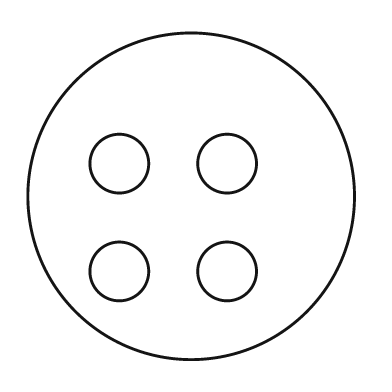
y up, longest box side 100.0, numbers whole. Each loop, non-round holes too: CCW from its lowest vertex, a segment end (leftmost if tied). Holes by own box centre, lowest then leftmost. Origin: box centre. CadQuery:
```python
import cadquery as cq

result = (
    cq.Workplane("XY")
    .moveTo(0.0, 0.0)
    .circle(50.0)
    .moveTo(-22.0, -23.0)
    .circle(9.0)
    .moveTo(11.0, -23.0)
    .circle(9.0)
    .moveTo(-22.0, 10.0)
    .circle(9.0)
    .moveTo(11.0, 10.0)
    .circle(9.0)
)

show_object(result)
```